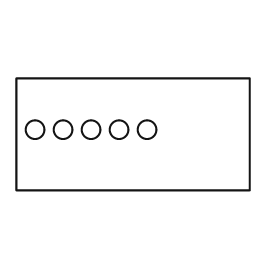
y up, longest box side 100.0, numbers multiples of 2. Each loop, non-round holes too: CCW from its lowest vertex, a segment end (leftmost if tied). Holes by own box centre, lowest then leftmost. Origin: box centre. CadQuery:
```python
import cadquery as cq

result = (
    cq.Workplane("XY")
    .moveTo(-50.0, -24.0)
    .lineTo(50.0, -24.0)
    .lineTo(50.0, 24.0)
    .lineTo(-50.0, 24.0)
    .close()
    .moveTo(-42.0, 2.0)
    .circle(4.0)
    .moveTo(-30.0, 2.0)
    .circle(4.0)
    .moveTo(-18.0, 2.0)
    .circle(4.0)
    .moveTo(-6.0, 2.0)
    .circle(4.0)
    .moveTo(6.0, 2.0)
    .circle(4.0)
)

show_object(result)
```